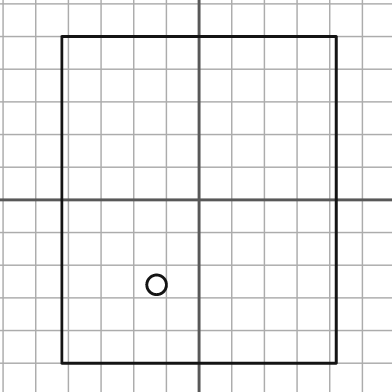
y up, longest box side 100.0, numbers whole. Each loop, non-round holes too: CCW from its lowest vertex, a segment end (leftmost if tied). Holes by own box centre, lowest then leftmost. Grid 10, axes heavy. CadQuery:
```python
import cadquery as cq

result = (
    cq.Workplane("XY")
    .moveTo(-42.0, -50.0)
    .lineTo(42.0, -50.0)
    .lineTo(42.0, 50.0)
    .lineTo(-42.0, 50.0)
    .close()
    .moveTo(-13.0, -26.0)
    .circle(3.0)
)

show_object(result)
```